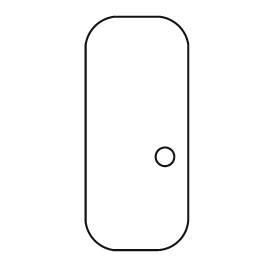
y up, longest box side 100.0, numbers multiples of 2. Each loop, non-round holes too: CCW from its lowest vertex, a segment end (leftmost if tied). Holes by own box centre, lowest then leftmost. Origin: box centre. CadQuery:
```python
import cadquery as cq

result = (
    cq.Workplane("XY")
    .moveTo(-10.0, -50.0)
    .lineTo(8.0, -50.0)
    .threePointArc((18.0, -46.0), (22.0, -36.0))
    .lineTo(22.0, 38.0)
    .threePointArc((18.0, 46.0), (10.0, 50.0))
    .lineTo(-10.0, 50.0)
    .threePointArc((-18.0, 46.0), (-22.0, 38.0))
    .lineTo(-22.0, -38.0)
    .threePointArc((-18.0, -46.0), (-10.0, -50.0))
    .close()
    .moveTo(12.0, -10.0)
    .circle(4.0)
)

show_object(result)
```